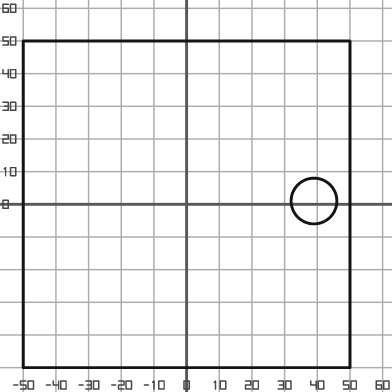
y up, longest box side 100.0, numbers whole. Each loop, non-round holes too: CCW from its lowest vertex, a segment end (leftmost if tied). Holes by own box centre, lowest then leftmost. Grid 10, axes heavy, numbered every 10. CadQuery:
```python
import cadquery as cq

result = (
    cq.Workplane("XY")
    .moveTo(-50.0, -50.0)
    .lineTo(50.0, -50.0)
    .lineTo(50.0, 50.0)
    .lineTo(-50.0, 50.0)
    .close()
    .moveTo(39.0, 1.0)
    .circle(7.0)
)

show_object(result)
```